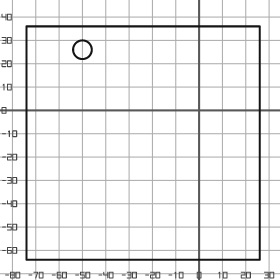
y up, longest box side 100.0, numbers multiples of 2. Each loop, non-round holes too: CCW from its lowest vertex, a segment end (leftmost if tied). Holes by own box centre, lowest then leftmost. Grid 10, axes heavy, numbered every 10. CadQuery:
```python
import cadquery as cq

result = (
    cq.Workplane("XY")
    .moveTo(-74.0, -64.0)
    .lineTo(26.0, -64.0)
    .lineTo(26.0, 36.0)
    .lineTo(-74.0, 36.0)
    .close()
    .moveTo(-50.0, 26.0)
    .circle(4.0)
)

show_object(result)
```